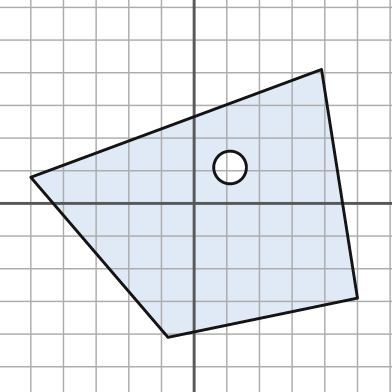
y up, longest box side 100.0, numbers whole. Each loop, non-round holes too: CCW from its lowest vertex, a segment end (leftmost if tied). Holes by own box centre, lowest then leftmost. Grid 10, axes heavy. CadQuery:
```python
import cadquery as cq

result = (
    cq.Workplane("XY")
    .moveTo(-8.0, -41.0)
    .lineTo(50.0, -29.0)
    .lineTo(39.0, 41.0)
    .lineTo(-50.0, 8.0)
    .close()
    .moveTo(11.0, 11.0)
    .circle(5.0)
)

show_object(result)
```